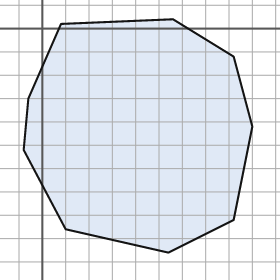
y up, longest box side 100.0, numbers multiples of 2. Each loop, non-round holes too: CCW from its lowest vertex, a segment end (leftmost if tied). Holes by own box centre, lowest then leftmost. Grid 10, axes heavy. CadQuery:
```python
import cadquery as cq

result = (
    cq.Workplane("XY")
    .moveTo(54.0, -96.0)
    .lineTo(82.0, -82.0)
    .lineTo(90.0, -42.0)
    .lineTo(82.0, -12.0)
    .lineTo(56.0, 4.0)
    .lineTo(8.0, 2.0)
    .lineTo(-6.0, -30.0)
    .lineTo(-8.0, -52.0)
    .lineTo(10.0, -86.0)
    .close()
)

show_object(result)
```